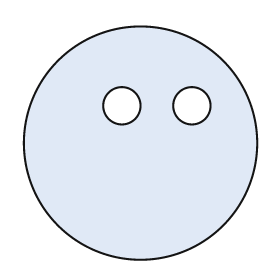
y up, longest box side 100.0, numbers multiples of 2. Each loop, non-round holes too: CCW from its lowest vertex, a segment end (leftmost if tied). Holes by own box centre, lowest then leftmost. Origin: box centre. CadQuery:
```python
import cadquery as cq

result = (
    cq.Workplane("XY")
    .moveTo(0.0, 0.0)
    .circle(50.0)
    .moveTo(-8.0, 16.0)
    .circle(8.0)
    .moveTo(22.0, 16.0)
    .circle(8.0)
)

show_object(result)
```